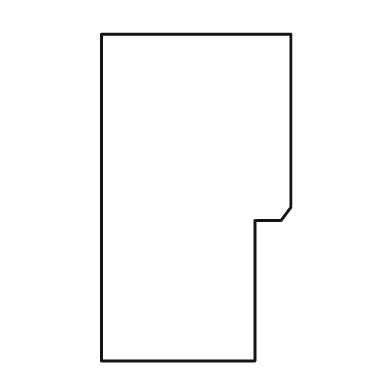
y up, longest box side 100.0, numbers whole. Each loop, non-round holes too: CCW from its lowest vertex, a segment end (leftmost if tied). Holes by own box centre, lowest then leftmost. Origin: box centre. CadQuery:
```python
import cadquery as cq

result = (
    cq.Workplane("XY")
    .moveTo(-29.0, -50.0)
    .lineTo(18.0, -50.0)
    .lineTo(18.0, -7.0)
    .lineTo(26.0, -7.0)
    .lineTo(29.0, -3.0)
    .lineTo(29.0, 50.0)
    .lineTo(-29.0, 50.0)
    .close()
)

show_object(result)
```